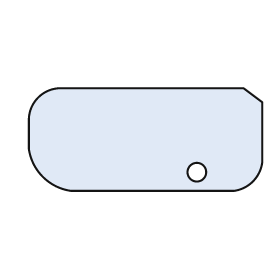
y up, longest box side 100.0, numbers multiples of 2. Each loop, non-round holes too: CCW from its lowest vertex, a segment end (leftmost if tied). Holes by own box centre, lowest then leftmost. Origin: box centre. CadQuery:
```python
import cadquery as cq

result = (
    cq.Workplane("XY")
    .moveTo(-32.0, -22.0)
    .lineTo(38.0, -22.0)
    .threePointArc((46.0, -18.0), (50.0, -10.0))
    .lineTo(50.0, 16.0)
    .lineTo(42.0, 22.0)
    .lineTo(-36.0, 22.0)
    .threePointArc((-46.0, 18.0), (-50.0, 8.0))
    .lineTo(-50.0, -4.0)
    .threePointArc((-44.0, -16.0), (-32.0, -22.0))
    .close()
    .moveTo(22.0, -14.0)
    .circle(4.0)
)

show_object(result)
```